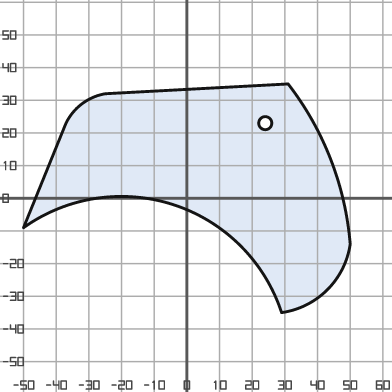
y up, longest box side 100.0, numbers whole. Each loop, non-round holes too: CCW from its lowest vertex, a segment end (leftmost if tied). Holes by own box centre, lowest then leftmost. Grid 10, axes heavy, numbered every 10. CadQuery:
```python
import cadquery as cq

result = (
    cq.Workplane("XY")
    .moveTo(29.0, -35.0)
    .threePointArc((43.0, -28.0), (50.0, -14.0))
    .threePointArc((44.0, 12.0), (31.0, 35.0))
    .lineTo(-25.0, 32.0)
    .threePointArc((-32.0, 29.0), (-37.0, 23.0))
    .lineTo(-50.0, -9.0)
    .threePointArc((-4.0, -2.0), (29.0, -35.0))
    .close()
    .moveTo(24.0, 23.0)
    .circle(2.0)
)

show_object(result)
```